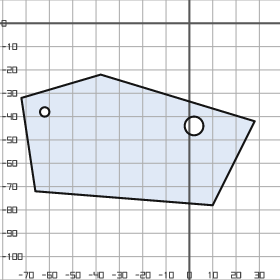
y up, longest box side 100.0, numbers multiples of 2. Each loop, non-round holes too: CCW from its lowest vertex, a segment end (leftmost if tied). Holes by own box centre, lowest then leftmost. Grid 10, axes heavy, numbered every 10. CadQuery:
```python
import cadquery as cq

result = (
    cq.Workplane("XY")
    .moveTo(10.0, -78.0)
    .lineTo(28.0, -42.0)
    .lineTo(-38.0, -22.0)
    .lineTo(-72.0, -32.0)
    .lineTo(-66.0, -72.0)
    .close()
    .moveTo(2.0, -44.0)
    .circle(4.0)
    .moveTo(-62.0, -38.0)
    .circle(2.0)
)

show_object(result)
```